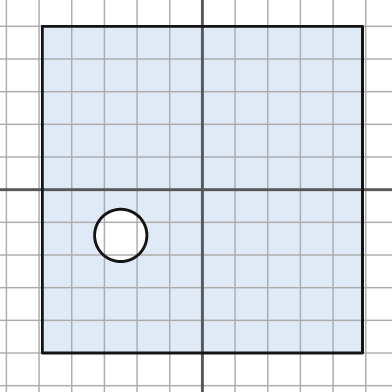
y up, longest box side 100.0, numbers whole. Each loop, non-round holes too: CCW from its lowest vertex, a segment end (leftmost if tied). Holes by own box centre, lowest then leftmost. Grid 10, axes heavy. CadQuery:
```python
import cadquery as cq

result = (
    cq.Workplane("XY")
    .moveTo(-49.0, -50.0)
    .lineTo(49.0, -50.0)
    .lineTo(49.0, 50.0)
    .lineTo(-49.0, 50.0)
    .close()
    .moveTo(-25.0, -14.0)
    .circle(8.0)
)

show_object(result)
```